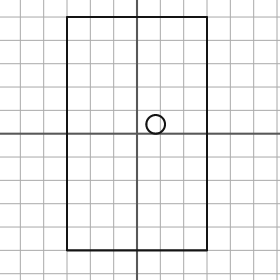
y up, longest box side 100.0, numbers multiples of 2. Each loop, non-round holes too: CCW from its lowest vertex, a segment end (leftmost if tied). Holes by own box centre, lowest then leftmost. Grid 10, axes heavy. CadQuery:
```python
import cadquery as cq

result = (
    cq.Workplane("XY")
    .moveTo(-30.0, -50.0)
    .lineTo(30.0, -50.0)
    .lineTo(30.0, 50.0)
    .lineTo(-30.0, 50.0)
    .close()
    .moveTo(8.0, 4.0)
    .circle(4.0)
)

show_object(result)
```